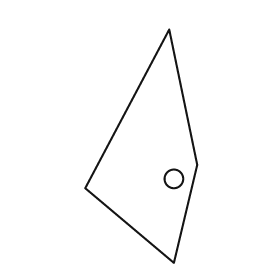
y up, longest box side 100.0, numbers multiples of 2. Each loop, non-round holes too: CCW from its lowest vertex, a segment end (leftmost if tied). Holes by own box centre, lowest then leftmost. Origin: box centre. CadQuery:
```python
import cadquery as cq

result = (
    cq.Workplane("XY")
    .moveTo(14.0, -50.0)
    .lineTo(24.0, -8.0)
    .lineTo(12.0, 50.0)
    .lineTo(-24.0, -18.0)
    .close()
    .moveTo(14.0, -14.0)
    .circle(4.0)
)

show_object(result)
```